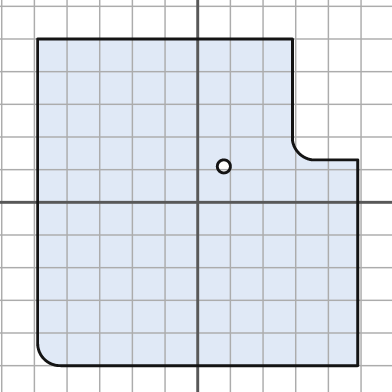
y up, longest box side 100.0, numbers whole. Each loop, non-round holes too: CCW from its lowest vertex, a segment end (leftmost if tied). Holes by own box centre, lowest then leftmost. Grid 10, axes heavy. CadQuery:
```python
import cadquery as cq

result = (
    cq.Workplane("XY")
    .moveTo(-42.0, -50.0)
    .lineTo(49.0, -50.0)
    .lineTo(49.0, 13.0)
    .lineTo(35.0, 13.0)
    .threePointArc((31.0, 15.0), (29.0, 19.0))
    .lineTo(29.0, 50.0)
    .lineTo(-49.0, 50.0)
    .lineTo(-49.0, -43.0)
    .threePointArc((-47.0, -48.0), (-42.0, -50.0))
    .close()
    .moveTo(8.0, 11.0)
    .circle(2.0)
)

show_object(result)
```